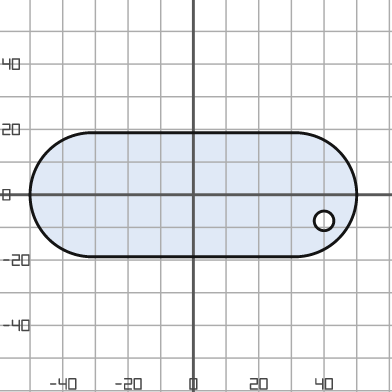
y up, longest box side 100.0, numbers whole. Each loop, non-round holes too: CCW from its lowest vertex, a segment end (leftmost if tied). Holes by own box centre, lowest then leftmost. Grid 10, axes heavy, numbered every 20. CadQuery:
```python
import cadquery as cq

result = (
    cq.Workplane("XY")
    .moveTo(-31.0, -19.0)
    .lineTo(31.0, -19.0)
    .threePointArc((50.0, 0.0), (31.0, 19.0))
    .lineTo(-31.0, 19.0)
    .threePointArc((-50.0, 0.0), (-31.0, -19.0))
    .close()
    .moveTo(40.0, -8.0)
    .circle(3.0)
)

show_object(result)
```